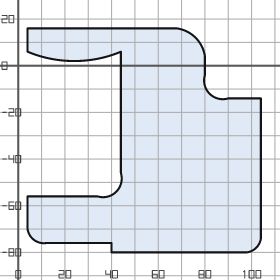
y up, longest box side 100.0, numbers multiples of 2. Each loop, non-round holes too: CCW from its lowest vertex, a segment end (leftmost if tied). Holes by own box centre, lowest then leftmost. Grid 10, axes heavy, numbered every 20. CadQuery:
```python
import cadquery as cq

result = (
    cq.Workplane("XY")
    .moveTo(40.0, -80.0)
    .lineTo(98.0, -80.0)
    .threePointArc((102.0, -78.0), (104.0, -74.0))
    .lineTo(104.0, -14.0)
    .lineTo(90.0, -14.0)
    .threePointArc((82.0, -12.0), (80.0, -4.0))
    .lineTo(80.0, 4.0)
    .threePointArc((76.0, 12.0), (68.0, 16.0))
    .lineTo(4.0, 16.0)
    .lineTo(4.0, 6.0)
    .threePointArc((24.0, 2.0), (44.0, 6.0))
    .lineTo(44.0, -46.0)
    .threePointArc((42.0, -54.0), (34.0, -56.0))
    .lineTo(4.0, -56.0)
    .lineTo(4.0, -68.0)
    .threePointArc((6.0, -74.0), (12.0, -76.0))
    .lineTo(40.0, -76.0)
    .close()
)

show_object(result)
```